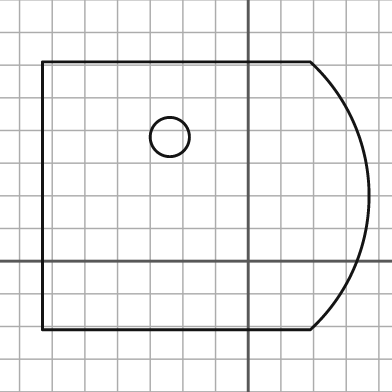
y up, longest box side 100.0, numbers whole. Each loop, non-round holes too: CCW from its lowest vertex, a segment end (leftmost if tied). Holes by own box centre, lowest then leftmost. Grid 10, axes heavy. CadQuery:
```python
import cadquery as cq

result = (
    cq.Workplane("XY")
    .moveTo(-63.0, -21.0)
    .lineTo(19.0, -21.0)
    .threePointArc((37.0, 20.0), (19.0, 61.0))
    .lineTo(-63.0, 61.0)
    .close()
    .moveTo(-24.0, 38.0)
    .circle(6.0)
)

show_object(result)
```